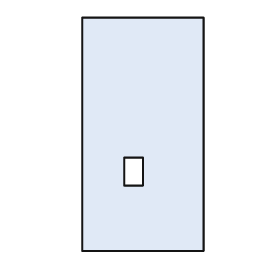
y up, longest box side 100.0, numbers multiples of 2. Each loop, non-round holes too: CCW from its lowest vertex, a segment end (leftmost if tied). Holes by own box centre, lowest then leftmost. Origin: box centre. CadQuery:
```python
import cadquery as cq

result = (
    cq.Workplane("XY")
    .moveTo(-26.0, -50.0)
    .lineTo(26.0, -50.0)
    .lineTo(26.0, 50.0)
    .lineTo(-26.0, 50.0)
    .close()
    .moveTo(-8.0, -22.0)
    .lineTo(0.0, -22.0)
    .lineTo(0.0, -10.0)
    .lineTo(-8.0, -10.0)
    .close()
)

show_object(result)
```